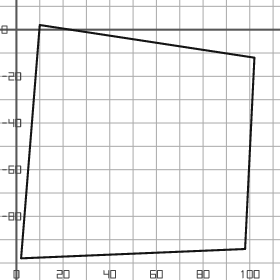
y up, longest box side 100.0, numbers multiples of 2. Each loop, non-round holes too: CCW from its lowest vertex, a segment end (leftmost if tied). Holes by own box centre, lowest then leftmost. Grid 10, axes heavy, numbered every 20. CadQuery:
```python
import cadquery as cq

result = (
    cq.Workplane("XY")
    .moveTo(2.0, -98.0)
    .lineTo(98.0, -94.0)
    .lineTo(102.0, -12.0)
    .lineTo(10.0, 2.0)
    .close()
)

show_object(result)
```